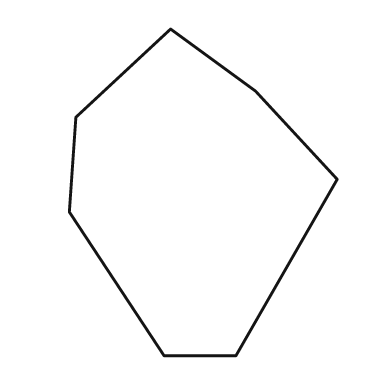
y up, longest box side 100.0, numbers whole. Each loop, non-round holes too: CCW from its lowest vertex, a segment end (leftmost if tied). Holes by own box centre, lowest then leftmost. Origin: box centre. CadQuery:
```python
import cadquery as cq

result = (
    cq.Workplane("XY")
    .moveTo(-12.0, -50.0)
    .lineTo(10.0, -50.0)
    .lineTo(41.0, 4.0)
    .lineTo(16.0, 31.0)
    .lineTo(-10.0, 50.0)
    .lineTo(-39.0, 23.0)
    .lineTo(-41.0, -6.0)
    .close()
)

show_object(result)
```